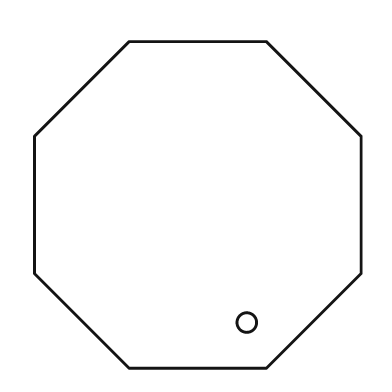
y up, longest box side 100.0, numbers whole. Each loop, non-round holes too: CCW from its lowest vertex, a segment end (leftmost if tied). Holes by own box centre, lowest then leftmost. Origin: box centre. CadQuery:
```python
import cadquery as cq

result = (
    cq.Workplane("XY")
    .moveTo(-21.0, -50.0)
    .lineTo(21.0, -50.0)
    .lineTo(50.0, -21.0)
    .lineTo(50.0, 21.0)
    .lineTo(21.0, 50.0)
    .lineTo(-21.0, 50.0)
    .lineTo(-50.0, 21.0)
    .lineTo(-50.0, -21.0)
    .close()
    .moveTo(15.0, -36.0)
    .circle(3.0)
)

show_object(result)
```